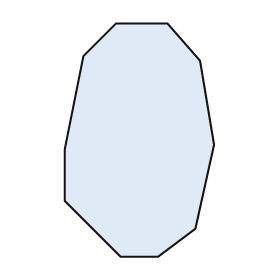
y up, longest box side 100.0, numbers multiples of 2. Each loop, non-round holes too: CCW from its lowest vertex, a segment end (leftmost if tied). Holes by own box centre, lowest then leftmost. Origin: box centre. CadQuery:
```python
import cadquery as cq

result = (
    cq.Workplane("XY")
    .moveTo(-8.0, -50.0)
    .lineTo(8.0, -50.0)
    .lineTo(24.0, -38.0)
    .lineTo(32.0, -2.0)
    .lineTo(26.0, 34.0)
    .lineTo(12.0, 50.0)
    .lineTo(-10.0, 50.0)
    .lineTo(-24.0, 36.0)
    .lineTo(-32.0, -4.0)
    .lineTo(-32.0, -26.0)
    .close()
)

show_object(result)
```